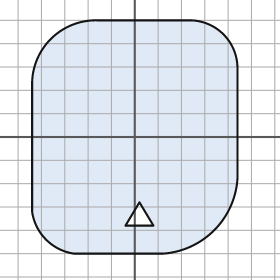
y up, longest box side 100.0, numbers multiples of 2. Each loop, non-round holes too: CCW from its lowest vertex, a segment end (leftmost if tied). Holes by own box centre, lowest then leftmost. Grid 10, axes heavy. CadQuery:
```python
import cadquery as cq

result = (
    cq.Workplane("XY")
    .moveTo(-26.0, -50.0)
    .lineTo(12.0, -50.0)
    .threePointArc((34.0, -40.0), (44.0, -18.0))
    .lineTo(44.0, 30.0)
    .threePointArc((38.0, 44.0), (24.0, 50.0))
    .lineTo(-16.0, 50.0)
    .threePointArc((-36.0, 42.0), (-44.0, 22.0))
    .lineTo(-44.0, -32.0)
    .threePointArc((-38.0, -44.0), (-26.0, -50.0))
    .close()
    .moveTo(-4.0, -38.0)
    .lineTo(8.0, -38.0)
    .lineTo(2.0, -28.0)
    .close()
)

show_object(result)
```